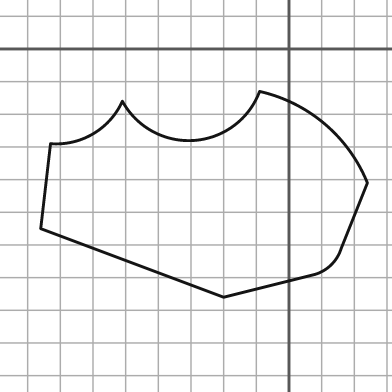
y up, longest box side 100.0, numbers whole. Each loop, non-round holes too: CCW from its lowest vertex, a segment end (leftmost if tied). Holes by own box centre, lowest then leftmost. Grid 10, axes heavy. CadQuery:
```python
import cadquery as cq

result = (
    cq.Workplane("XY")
    .moveTo(-20.0, -76.0)
    .lineTo(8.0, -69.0)
    .threePointArc((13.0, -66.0), (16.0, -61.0))
    .lineTo(24.0, -41.0)
    .threePointArc((11.0, -23.0), (-9.0, -13.0))
    .threePointArc((-29.0, -28.0), (-51.0, -16.0))
    .threePointArc((-60.0, -26.0), (-73.0, -29.0))
    .lineTo(-76.0, -55.0)
    .close()
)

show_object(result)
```